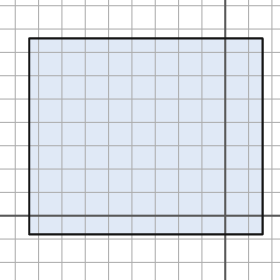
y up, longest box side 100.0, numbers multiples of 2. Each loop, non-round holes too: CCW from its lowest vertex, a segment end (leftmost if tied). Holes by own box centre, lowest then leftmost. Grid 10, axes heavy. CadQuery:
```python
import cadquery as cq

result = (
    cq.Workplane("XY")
    .moveTo(-84.0, -8.0)
    .lineTo(16.0, -8.0)
    .lineTo(16.0, 76.0)
    .lineTo(-84.0, 76.0)
    .close()
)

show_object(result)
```